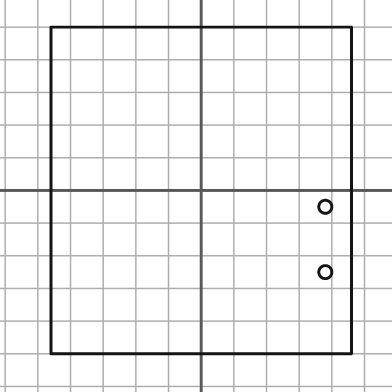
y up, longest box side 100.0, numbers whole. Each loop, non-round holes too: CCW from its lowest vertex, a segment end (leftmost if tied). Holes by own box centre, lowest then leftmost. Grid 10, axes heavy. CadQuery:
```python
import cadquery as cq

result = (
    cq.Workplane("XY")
    .moveTo(-46.0, -50.0)
    .lineTo(46.0, -50.0)
    .lineTo(46.0, 50.0)
    .lineTo(-46.0, 50.0)
    .close()
    .moveTo(38.0, -25.0)
    .circle(2.0)
    .moveTo(38.0, -5.0)
    .circle(2.0)
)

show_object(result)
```